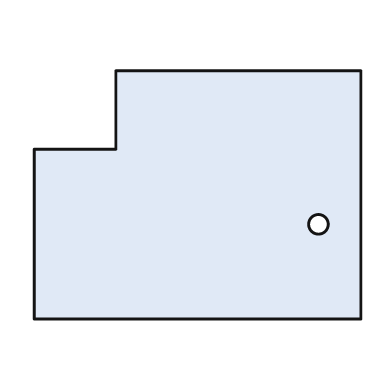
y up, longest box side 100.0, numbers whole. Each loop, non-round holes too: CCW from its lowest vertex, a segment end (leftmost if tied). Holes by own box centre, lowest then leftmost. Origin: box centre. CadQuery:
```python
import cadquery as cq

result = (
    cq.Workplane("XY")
    .moveTo(-50.0, -38.0)
    .lineTo(50.0, -38.0)
    .lineTo(50.0, 38.0)
    .lineTo(-25.0, 38.0)
    .lineTo(-25.0, 14.0)
    .lineTo(-50.0, 14.0)
    .close()
    .moveTo(37.0, -9.0)
    .circle(3.0)
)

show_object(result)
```